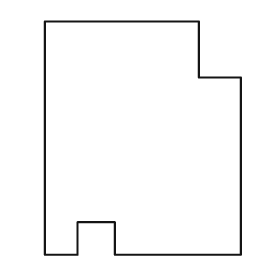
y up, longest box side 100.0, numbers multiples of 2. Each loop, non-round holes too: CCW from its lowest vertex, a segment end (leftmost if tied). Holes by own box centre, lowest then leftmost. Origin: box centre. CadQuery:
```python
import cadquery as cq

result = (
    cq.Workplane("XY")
    .moveTo(-42.0, -50.0)
    .lineTo(-28.0, -50.0)
    .lineTo(-28.0, -36.0)
    .lineTo(-12.0, -36.0)
    .lineTo(-12.0, -50.0)
    .lineTo(42.0, -50.0)
    .lineTo(42.0, 26.0)
    .lineTo(24.0, 26.0)
    .lineTo(24.0, 50.0)
    .lineTo(-42.0, 50.0)
    .close()
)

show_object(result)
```